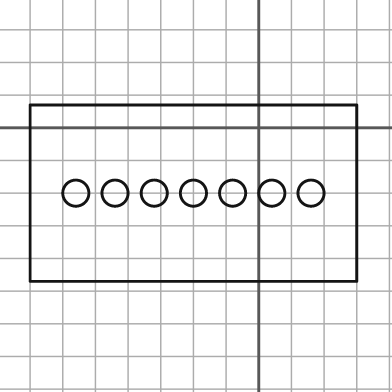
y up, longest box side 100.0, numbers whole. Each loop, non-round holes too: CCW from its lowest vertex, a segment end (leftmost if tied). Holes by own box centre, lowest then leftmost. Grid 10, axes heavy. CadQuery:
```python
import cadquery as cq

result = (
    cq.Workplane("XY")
    .moveTo(-70.0, -47.0)
    .lineTo(30.0, -47.0)
    .lineTo(30.0, 7.0)
    .lineTo(-70.0, 7.0)
    .close()
    .moveTo(-56.0, -20.0)
    .circle(4.0)
    .moveTo(-44.0, -20.0)
    .circle(4.0)
    .moveTo(-32.0, -20.0)
    .circle(4.0)
    .moveTo(-20.0, -20.0)
    .circle(4.0)
    .moveTo(-8.0, -20.0)
    .circle(4.0)
    .moveTo(4.0, -20.0)
    .circle(4.0)
    .moveTo(16.0, -20.0)
    .circle(4.0)
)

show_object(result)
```